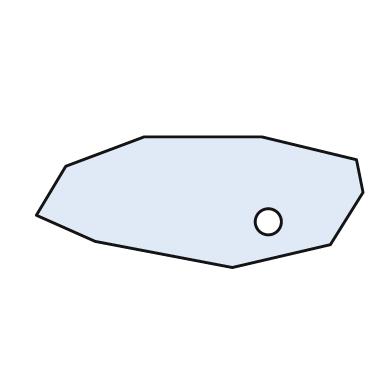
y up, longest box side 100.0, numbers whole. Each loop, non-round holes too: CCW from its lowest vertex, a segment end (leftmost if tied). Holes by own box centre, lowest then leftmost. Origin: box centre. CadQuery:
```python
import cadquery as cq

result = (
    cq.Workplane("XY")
    .moveTo(10.0, -20.0)
    .lineTo(40.0, -13.0)
    .lineTo(50.0, 3.0)
    .lineTo(48.0, 13.0)
    .lineTo(19.0, 20.0)
    .lineTo(-17.0, 20.0)
    .lineTo(-41.0, 11.0)
    .lineTo(-50.0, -4.0)
    .lineTo(-32.0, -12.0)
    .close()
    .moveTo(21.0, -6.0)
    .circle(4.0)
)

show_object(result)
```